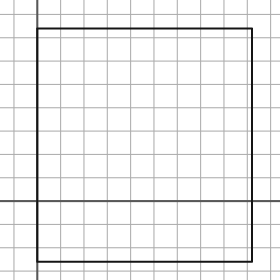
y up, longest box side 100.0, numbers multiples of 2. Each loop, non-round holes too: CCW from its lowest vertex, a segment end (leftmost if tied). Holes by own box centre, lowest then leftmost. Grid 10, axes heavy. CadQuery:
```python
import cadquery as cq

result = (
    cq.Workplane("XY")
    .moveTo(0.0, -26.0)
    .lineTo(92.0, -26.0)
    .lineTo(92.0, 74.0)
    .lineTo(0.0, 74.0)
    .close()
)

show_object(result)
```